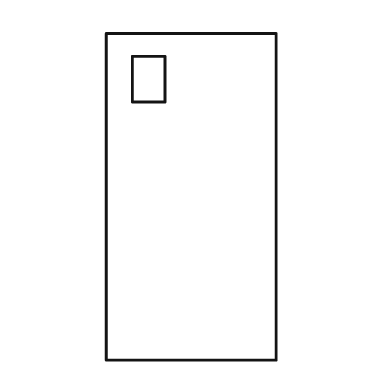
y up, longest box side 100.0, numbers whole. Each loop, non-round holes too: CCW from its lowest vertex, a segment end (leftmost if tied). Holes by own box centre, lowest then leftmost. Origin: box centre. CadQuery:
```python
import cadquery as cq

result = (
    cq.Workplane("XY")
    .moveTo(-26.0, -50.0)
    .lineTo(26.0, -50.0)
    .lineTo(26.0, 50.0)
    .lineTo(-26.0, 50.0)
    .close()
    .moveTo(-18.0, 29.0)
    .lineTo(-8.0, 29.0)
    .lineTo(-8.0, 43.0)
    .lineTo(-18.0, 43.0)
    .close()
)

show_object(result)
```